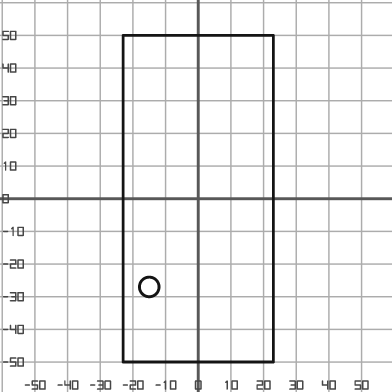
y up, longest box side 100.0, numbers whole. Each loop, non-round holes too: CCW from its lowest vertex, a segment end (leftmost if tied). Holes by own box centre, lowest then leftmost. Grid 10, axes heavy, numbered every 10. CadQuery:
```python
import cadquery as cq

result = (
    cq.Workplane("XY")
    .moveTo(-23.0, -50.0)
    .lineTo(23.0, -50.0)
    .lineTo(23.0, 50.0)
    .lineTo(-23.0, 50.0)
    .close()
    .moveTo(-15.0, -27.0)
    .circle(3.0)
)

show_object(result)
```